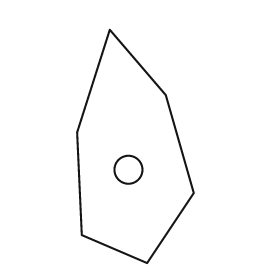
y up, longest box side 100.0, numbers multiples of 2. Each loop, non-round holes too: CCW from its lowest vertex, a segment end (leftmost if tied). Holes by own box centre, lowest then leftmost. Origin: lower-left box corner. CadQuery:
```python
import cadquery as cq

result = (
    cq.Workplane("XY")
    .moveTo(30.0, 0.0)
    .lineTo(50.0, 30.0)
    .lineTo(38.0, 72.0)
    .lineTo(14.0, 100.0)
    .lineTo(0.0, 56.0)
    .lineTo(2.0, 12.0)
    .close()
    .moveTo(22.0, 40.0)
    .circle(6.0)
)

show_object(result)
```